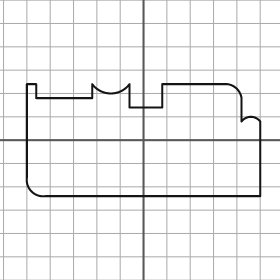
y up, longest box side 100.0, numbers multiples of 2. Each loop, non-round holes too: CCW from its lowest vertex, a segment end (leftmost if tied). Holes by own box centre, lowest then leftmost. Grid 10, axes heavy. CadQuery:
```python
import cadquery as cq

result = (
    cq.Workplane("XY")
    .moveTo(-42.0, -24.0)
    .lineTo(50.0, -24.0)
    .lineTo(50.0, 8.0)
    .threePointArc((46.0, 10.0), (42.0, 8.0))
    .lineTo(42.0, 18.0)
    .threePointArc((40.0, 22.0), (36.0, 24.0))
    .lineTo(8.0, 24.0)
    .lineTo(8.0, 14.0)
    .lineTo(-6.0, 14.0)
    .lineTo(-6.0, 24.0)
    .threePointArc((-14.0, 20.0), (-22.0, 24.0))
    .lineTo(-22.0, 18.0)
    .lineTo(-46.0, 18.0)
    .lineTo(-46.0, 24.0)
    .lineTo(-50.0, 24.0)
    .lineTo(-50.0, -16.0)
    .threePointArc((-48.0, -22.0), (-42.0, -24.0))
    .close()
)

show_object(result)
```